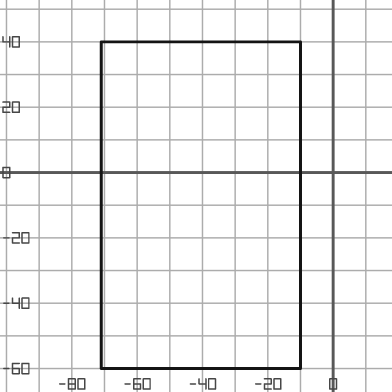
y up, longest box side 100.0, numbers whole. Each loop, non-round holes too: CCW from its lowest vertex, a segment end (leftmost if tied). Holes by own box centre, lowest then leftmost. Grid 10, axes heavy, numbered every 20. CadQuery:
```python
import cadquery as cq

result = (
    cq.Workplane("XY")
    .moveTo(-71.0, -60.0)
    .lineTo(-10.0, -60.0)
    .lineTo(-10.0, 40.0)
    .lineTo(-71.0, 40.0)
    .close()
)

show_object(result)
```